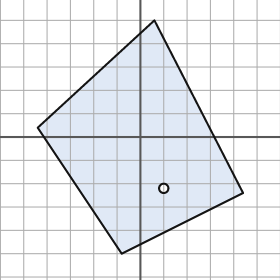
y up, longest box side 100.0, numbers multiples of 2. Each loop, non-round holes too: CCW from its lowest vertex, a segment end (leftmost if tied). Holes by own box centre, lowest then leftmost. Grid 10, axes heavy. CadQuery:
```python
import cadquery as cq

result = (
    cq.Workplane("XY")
    .moveTo(-8.0, -50.0)
    .lineTo(44.0, -24.0)
    .lineTo(6.0, 50.0)
    .lineTo(-44.0, 4.0)
    .close()
    .moveTo(10.0, -22.0)
    .circle(2.0)
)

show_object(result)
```